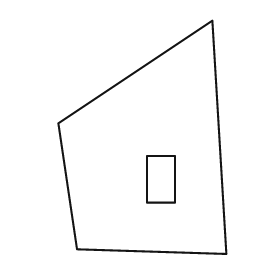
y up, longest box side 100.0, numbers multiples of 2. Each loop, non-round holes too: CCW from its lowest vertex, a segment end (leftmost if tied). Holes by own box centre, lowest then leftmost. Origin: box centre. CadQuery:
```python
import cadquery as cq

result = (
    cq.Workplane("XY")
    .moveTo(36.0, -50.0)
    .lineTo(30.0, 50.0)
    .lineTo(-36.0, 6.0)
    .lineTo(-28.0, -48.0)
    .close()
    .moveTo(2.0, -28.0)
    .lineTo(14.0, -28.0)
    .lineTo(14.0, -8.0)
    .lineTo(2.0, -8.0)
    .close()
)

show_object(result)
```